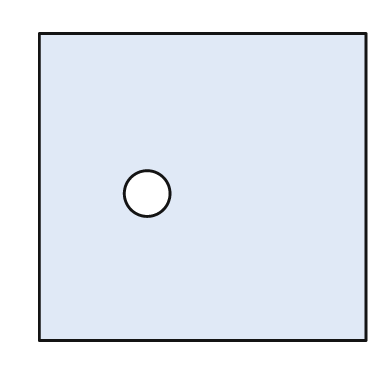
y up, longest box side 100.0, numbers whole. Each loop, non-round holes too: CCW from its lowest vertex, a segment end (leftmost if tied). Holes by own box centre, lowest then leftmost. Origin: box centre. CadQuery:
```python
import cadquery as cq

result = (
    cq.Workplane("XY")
    .moveTo(-50.0, -47.0)
    .lineTo(50.0, -47.0)
    .lineTo(50.0, 47.0)
    .lineTo(-50.0, 47.0)
    .close()
    .moveTo(-17.0, -2.0)
    .circle(7.0)
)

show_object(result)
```